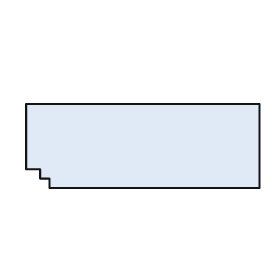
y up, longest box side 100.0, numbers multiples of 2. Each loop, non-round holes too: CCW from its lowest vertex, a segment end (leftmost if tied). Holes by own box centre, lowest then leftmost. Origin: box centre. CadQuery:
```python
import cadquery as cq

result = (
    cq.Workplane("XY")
    .moveTo(-40.0, -18.0)
    .lineTo(50.0, -18.0)
    .lineTo(50.0, 18.0)
    .lineTo(-50.0, 18.0)
    .lineTo(-50.0, -10.0)
    .lineTo(-44.0, -10.0)
    .lineTo(-44.0, -14.0)
    .lineTo(-40.0, -14.0)
    .close()
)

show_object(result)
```